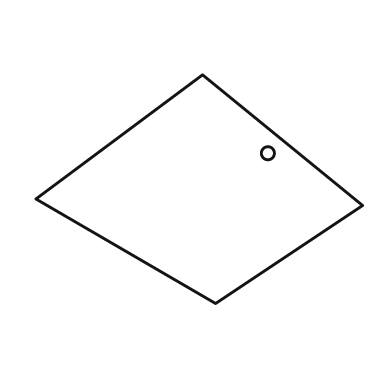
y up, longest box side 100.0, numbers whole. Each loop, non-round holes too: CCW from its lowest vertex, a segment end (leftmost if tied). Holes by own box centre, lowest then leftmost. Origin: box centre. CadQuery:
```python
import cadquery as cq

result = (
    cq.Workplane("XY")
    .moveTo(5.0, -35.0)
    .lineTo(50.0, -5.0)
    .lineTo(1.0, 35.0)
    .lineTo(-50.0, -3.0)
    .close()
    .moveTo(21.0, 11.0)
    .circle(2.0)
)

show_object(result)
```